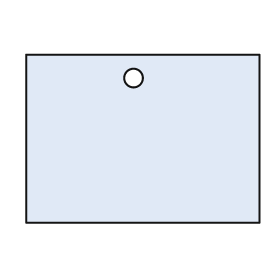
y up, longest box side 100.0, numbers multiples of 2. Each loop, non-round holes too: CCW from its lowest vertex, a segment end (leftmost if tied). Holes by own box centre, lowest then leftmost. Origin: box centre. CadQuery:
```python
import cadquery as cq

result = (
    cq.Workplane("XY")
    .moveTo(-50.0, -36.0)
    .lineTo(50.0, -36.0)
    .lineTo(50.0, 36.0)
    .lineTo(-50.0, 36.0)
    .close()
    .moveTo(-4.0, 26.0)
    .circle(4.0)
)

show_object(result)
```